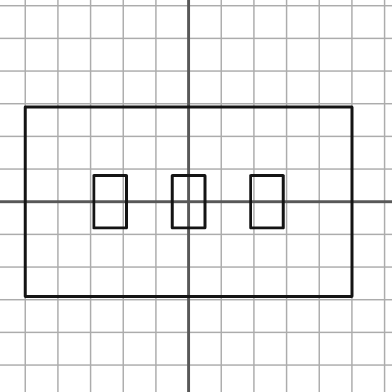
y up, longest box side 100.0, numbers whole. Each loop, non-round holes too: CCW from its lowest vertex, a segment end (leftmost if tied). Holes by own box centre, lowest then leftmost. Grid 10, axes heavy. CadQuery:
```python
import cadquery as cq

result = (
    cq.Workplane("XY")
    .moveTo(-50.0, -29.0)
    .lineTo(50.0, -29.0)
    .lineTo(50.0, 29.0)
    .lineTo(-50.0, 29.0)
    .close()
    .moveTo(-29.0, -8.0)
    .lineTo(-19.0, -8.0)
    .lineTo(-19.0, 8.0)
    .lineTo(-29.0, 8.0)
    .close()
    .moveTo(-5.0, -8.0)
    .lineTo(5.0, -8.0)
    .lineTo(5.0, 8.0)
    .lineTo(-5.0, 8.0)
    .close()
    .moveTo(19.0, -8.0)
    .lineTo(29.0, -8.0)
    .lineTo(29.0, 8.0)
    .lineTo(19.0, 8.0)
    .close()
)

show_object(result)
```